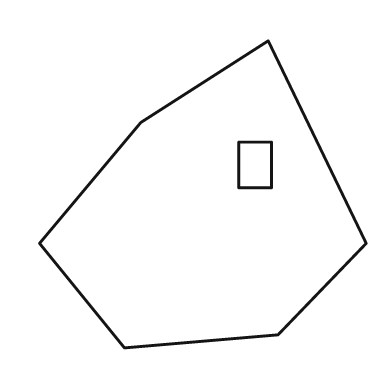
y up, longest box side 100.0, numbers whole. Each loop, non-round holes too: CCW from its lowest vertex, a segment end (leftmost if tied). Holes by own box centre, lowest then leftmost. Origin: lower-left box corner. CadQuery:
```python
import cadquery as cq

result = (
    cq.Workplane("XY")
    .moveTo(26.0, 0.0)
    .lineTo(73.0, 4.0)
    .lineTo(100.0, 32.0)
    .lineTo(70.0, 94.0)
    .lineTo(31.0, 69.0)
    .lineTo(0.0, 32.0)
    .close()
    .moveTo(61.0, 49.0)
    .lineTo(71.0, 49.0)
    .lineTo(71.0, 63.0)
    .lineTo(61.0, 63.0)
    .close()
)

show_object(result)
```